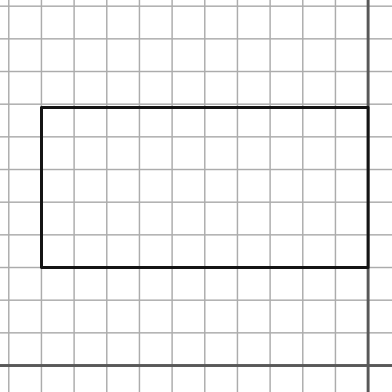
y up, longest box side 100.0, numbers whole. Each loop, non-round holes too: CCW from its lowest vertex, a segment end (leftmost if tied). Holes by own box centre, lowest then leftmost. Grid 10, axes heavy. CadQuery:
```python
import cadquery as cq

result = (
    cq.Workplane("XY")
    .moveTo(-100.0, 30.0)
    .lineTo(0.0, 30.0)
    .lineTo(0.0, 79.0)
    .lineTo(-100.0, 79.0)
    .close()
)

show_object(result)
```